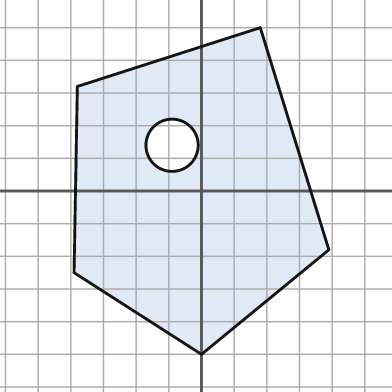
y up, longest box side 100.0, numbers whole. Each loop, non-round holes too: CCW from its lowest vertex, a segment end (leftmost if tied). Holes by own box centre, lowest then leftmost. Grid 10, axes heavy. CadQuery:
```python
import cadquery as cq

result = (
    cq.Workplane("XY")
    .moveTo(0.0, -50.0)
    .lineTo(39.0, -18.0)
    .lineTo(18.0, 50.0)
    .lineTo(-38.0, 32.0)
    .lineTo(-39.0, -25.0)
    .close()
    .moveTo(-9.0, 14.0)
    .circle(8.0)
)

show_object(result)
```